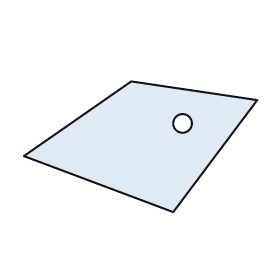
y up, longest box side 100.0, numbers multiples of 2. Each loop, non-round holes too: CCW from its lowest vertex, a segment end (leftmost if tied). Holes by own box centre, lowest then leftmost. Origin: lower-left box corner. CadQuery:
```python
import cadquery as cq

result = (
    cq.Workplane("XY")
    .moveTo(64.0, 0.0)
    .lineTo(100.0, 48.0)
    .lineTo(46.0, 56.0)
    .lineTo(0.0, 24.0)
    .close()
    .moveTo(68.0, 38.0)
    .circle(4.0)
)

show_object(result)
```